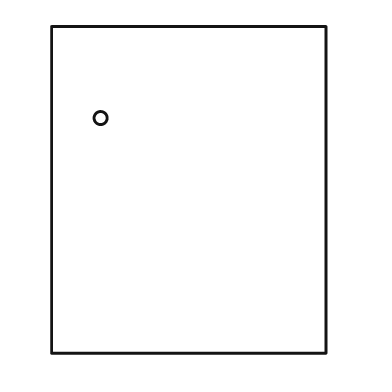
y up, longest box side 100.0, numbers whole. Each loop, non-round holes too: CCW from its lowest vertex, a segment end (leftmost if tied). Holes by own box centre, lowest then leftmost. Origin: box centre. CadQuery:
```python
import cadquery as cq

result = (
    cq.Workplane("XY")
    .moveTo(-42.0, -50.0)
    .lineTo(42.0, -50.0)
    .lineTo(42.0, 50.0)
    .lineTo(-42.0, 50.0)
    .close()
    .moveTo(-27.0, 22.0)
    .circle(2.0)
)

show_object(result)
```